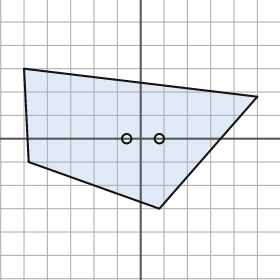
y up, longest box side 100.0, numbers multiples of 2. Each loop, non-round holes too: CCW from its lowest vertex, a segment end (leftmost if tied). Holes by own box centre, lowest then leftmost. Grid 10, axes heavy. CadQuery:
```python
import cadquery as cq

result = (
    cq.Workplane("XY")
    .moveTo(8.0, -30.0)
    .lineTo(50.0, 18.0)
    .lineTo(-50.0, 30.0)
    .lineTo(-48.0, -10.0)
    .close()
    .moveTo(-6.0, 0.0)
    .circle(2.0)
    .moveTo(8.0, 0.0)
    .circle(2.0)
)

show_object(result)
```